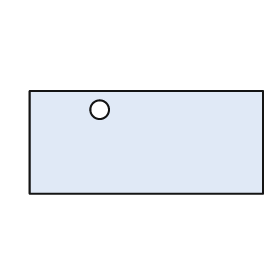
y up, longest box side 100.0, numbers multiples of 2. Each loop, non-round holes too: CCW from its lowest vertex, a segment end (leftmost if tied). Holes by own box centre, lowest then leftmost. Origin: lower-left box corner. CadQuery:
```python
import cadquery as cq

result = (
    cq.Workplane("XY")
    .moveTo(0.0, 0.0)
    .lineTo(100.0, 0.0)
    .lineTo(100.0, 44.0)
    .lineTo(0.0, 44.0)
    .close()
    .moveTo(30.0, 36.0)
    .circle(4.0)
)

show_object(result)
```